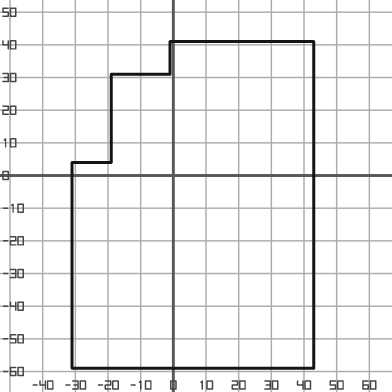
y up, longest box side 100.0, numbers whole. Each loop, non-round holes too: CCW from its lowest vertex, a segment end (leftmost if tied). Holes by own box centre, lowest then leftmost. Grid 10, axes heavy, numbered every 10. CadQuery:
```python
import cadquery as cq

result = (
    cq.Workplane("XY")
    .moveTo(-31.0, -59.0)
    .lineTo(43.0, -59.0)
    .lineTo(43.0, 41.0)
    .lineTo(-1.0, 41.0)
    .lineTo(-1.0, 31.0)
    .lineTo(-19.0, 31.0)
    .lineTo(-19.0, 4.0)
    .lineTo(-31.0, 4.0)
    .close()
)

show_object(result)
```